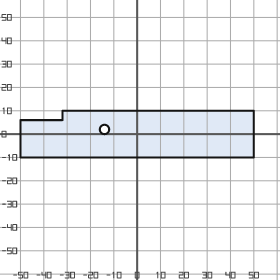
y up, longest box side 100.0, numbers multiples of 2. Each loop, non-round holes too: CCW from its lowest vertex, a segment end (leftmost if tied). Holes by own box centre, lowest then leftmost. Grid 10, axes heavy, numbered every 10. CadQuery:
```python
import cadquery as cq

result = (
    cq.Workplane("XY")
    .moveTo(-50.0, -10.0)
    .lineTo(50.0, -10.0)
    .lineTo(50.0, 10.0)
    .lineTo(-32.0, 10.0)
    .lineTo(-32.0, 6.0)
    .lineTo(-50.0, 6.0)
    .close()
    .moveTo(-14.0, 2.0)
    .circle(2.0)
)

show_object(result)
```